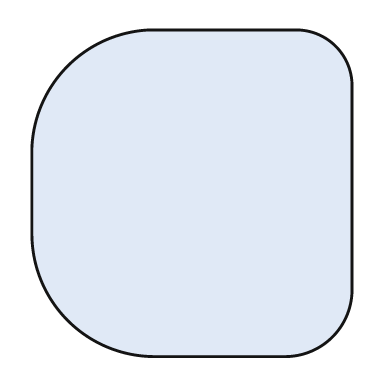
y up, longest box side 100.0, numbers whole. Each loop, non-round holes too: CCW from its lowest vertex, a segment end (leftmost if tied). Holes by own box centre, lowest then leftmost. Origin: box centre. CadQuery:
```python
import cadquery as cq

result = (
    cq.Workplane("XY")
    .moveTo(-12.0, -50.0)
    .lineTo(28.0, -50.0)
    .threePointArc((43.0, -44.0), (49.0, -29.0))
    .lineTo(49.0, 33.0)
    .threePointArc((44.0, 45.0), (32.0, 50.0))
    .lineTo(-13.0, 50.0)
    .threePointArc((-38.0, 39.0), (-49.0, 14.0))
    .lineTo(-49.0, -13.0)
    .threePointArc((-38.0, -39.0), (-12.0, -50.0))
    .close()
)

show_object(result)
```